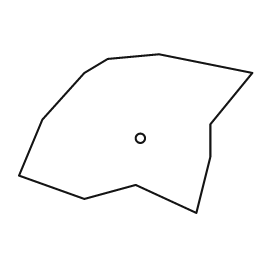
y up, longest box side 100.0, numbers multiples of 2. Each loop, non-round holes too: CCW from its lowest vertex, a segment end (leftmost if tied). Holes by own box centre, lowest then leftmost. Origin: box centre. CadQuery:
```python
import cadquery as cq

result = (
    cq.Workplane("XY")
    .moveTo(26.0, -34.0)
    .lineTo(32.0, -10.0)
    .lineTo(32.0, 4.0)
    .lineTo(50.0, 26.0)
    .lineTo(10.0, 34.0)
    .lineTo(-12.0, 32.0)
    .lineTo(-22.0, 26.0)
    .lineTo(-40.0, 6.0)
    .lineTo(-50.0, -18.0)
    .lineTo(-22.0, -28.0)
    .lineTo(0.0, -22.0)
    .close()
    .moveTo(2.0, -2.0)
    .circle(2.0)
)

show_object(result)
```